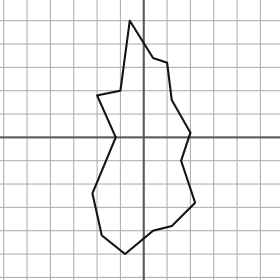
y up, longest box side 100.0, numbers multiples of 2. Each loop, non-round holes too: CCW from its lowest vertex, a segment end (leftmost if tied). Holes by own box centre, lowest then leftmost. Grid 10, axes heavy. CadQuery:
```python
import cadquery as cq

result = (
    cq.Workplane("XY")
    .moveTo(-8.0, -50.0)
    .lineTo(4.0, -40.0)
    .lineTo(12.0, -38.0)
    .lineTo(22.0, -28.0)
    .lineTo(16.0, -10.0)
    .lineTo(20.0, 2.0)
    .lineTo(12.0, 16.0)
    .lineTo(10.0, 32.0)
    .lineTo(4.0, 34.0)
    .lineTo(-6.0, 50.0)
    .lineTo(-10.0, 20.0)
    .lineTo(-20.0, 18.0)
    .lineTo(-12.0, 0.0)
    .lineTo(-22.0, -24.0)
    .lineTo(-18.0, -42.0)
    .close()
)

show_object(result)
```